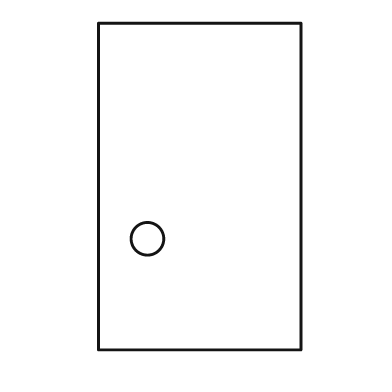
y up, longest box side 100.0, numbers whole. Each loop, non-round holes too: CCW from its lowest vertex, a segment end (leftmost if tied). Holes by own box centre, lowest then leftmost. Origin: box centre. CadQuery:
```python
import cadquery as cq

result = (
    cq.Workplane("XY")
    .moveTo(-31.0, -50.0)
    .lineTo(31.0, -50.0)
    .lineTo(31.0, 50.0)
    .lineTo(-31.0, 50.0)
    .close()
    .moveTo(-16.0, -16.0)
    .circle(5.0)
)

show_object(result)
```